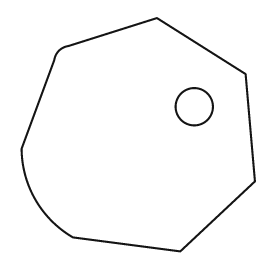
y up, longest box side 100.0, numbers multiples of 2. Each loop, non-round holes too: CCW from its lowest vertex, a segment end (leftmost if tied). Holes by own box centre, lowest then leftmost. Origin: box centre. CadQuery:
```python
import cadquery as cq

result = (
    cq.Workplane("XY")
    .moveTo(18.0, -50.0)
    .lineTo(50.0, -20.0)
    .lineTo(46.0, 26.0)
    .lineTo(8.0, 50.0)
    .lineTo(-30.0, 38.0)
    .threePointArc((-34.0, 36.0), (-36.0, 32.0))
    .lineTo(-50.0, -6.0)
    .threePointArc((-44.0, -28.0), (-28.0, -44.0))
    .close()
    .moveTo(24.0, 12.0)
    .circle(8.0)
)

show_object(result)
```